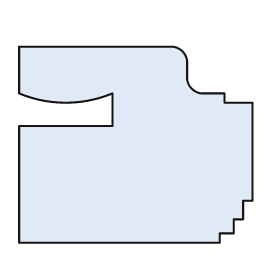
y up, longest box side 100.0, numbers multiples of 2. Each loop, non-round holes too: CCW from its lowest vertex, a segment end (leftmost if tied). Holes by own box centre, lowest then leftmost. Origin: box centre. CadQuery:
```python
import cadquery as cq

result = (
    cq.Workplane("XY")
    .moveTo(-50.0, -42.0)
    .lineTo(36.0, -42.0)
    .lineTo(36.0, -38.0)
    .lineTo(42.0, -38.0)
    .lineTo(42.0, -32.0)
    .lineTo(46.0, -32.0)
    .lineTo(46.0, -24.0)
    .lineTo(50.0, -24.0)
    .lineTo(50.0, 18.0)
    .lineTo(38.0, 18.0)
    .lineTo(38.0, 22.0)
    .lineTo(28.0, 22.0)
    .threePointArc((24.0, 24.0), (22.0, 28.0))
    .lineTo(22.0, 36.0)
    .threePointArc((20.0, 40.0), (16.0, 42.0))
    .lineTo(-50.0, 42.0)
    .lineTo(-50.0, 22.0)
    .threePointArc((-30.0, 18.0), (-10.0, 22.0))
    .lineTo(-10.0, 8.0)
    .lineTo(-50.0, 8.0)
    .close()
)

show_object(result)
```